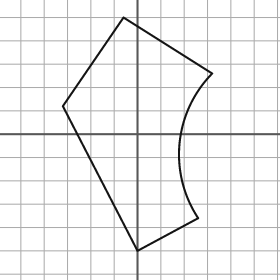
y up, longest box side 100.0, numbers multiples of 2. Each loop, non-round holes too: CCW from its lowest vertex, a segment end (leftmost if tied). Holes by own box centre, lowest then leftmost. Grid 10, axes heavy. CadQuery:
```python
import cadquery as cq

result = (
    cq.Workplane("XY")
    .moveTo(0.0, -50.0)
    .lineTo(26.0, -36.0)
    .threePointArc((18.0, -4.0), (32.0, 26.0))
    .lineTo(-6.0, 50.0)
    .lineTo(-32.0, 12.0)
    .close()
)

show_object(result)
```